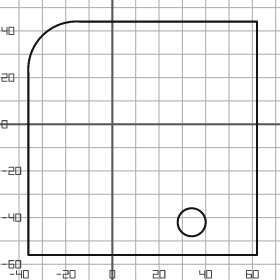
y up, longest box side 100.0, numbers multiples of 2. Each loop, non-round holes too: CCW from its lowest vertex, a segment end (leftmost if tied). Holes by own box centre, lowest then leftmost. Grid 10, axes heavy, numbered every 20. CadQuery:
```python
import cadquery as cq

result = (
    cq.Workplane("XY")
    .moveTo(-36.0, -56.0)
    .lineTo(62.0, -56.0)
    .lineTo(62.0, 44.0)
    .lineTo(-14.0, 44.0)
    .threePointArc((-30.0, 38.0), (-36.0, 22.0))
    .close()
    .moveTo(34.0, -42.0)
    .circle(6.0)
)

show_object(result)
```